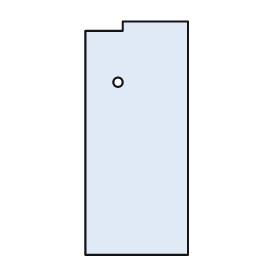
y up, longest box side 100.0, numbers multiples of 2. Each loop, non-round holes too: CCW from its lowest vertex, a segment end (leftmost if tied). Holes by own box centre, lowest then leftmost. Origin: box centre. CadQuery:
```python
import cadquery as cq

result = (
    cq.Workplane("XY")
    .moveTo(-22.0, -50.0)
    .lineTo(22.0, -50.0)
    .lineTo(22.0, 50.0)
    .lineTo(-6.0, 50.0)
    .lineTo(-6.0, 46.0)
    .lineTo(-22.0, 46.0)
    .close()
    .moveTo(-8.0, 24.0)
    .circle(2.0)
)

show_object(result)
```